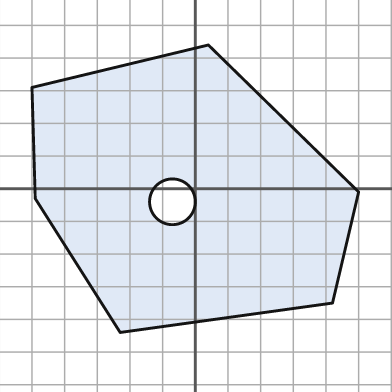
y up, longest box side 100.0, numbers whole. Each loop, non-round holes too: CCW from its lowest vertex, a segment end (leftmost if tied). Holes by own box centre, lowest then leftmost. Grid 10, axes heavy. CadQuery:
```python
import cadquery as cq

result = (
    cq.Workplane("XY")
    .moveTo(-23.0, -44.0)
    .lineTo(42.0, -35.0)
    .lineTo(50.0, -1.0)
    .lineTo(4.0, 44.0)
    .lineTo(-50.0, 31.0)
    .lineTo(-49.0, -3.0)
    .close()
    .moveTo(-7.0, -4.0)
    .circle(7.0)
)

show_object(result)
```